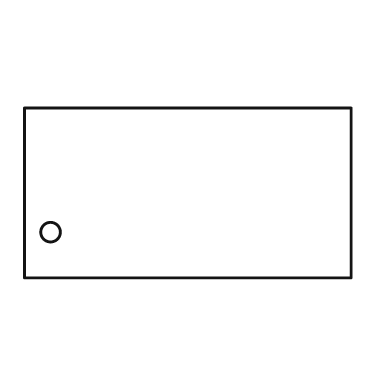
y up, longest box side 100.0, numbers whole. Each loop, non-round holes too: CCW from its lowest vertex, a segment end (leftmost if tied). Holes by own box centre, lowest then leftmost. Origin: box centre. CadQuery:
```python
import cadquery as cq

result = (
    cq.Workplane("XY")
    .moveTo(-50.0, -26.0)
    .lineTo(50.0, -26.0)
    .lineTo(50.0, 26.0)
    .lineTo(-50.0, 26.0)
    .close()
    .moveTo(-42.0, -12.0)
    .circle(3.0)
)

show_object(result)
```